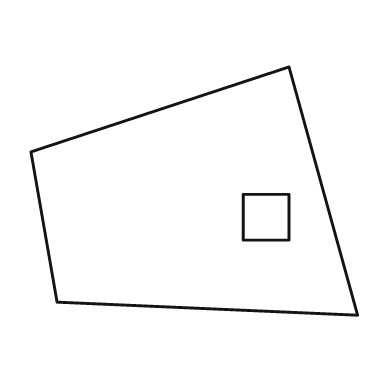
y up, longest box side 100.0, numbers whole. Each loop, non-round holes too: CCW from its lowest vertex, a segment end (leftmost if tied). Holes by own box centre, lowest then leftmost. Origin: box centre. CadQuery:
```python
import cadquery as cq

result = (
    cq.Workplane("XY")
    .moveTo(50.0, -38.0)
    .lineTo(29.0, 38.0)
    .lineTo(-50.0, 12.0)
    .lineTo(-42.0, -34.0)
    .close()
    .moveTo(15.0, -15.0)
    .lineTo(29.0, -15.0)
    .lineTo(29.0, -1.0)
    .lineTo(15.0, -1.0)
    .close()
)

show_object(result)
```